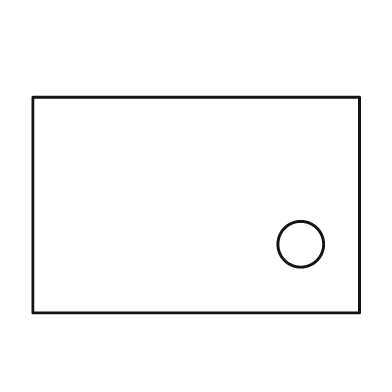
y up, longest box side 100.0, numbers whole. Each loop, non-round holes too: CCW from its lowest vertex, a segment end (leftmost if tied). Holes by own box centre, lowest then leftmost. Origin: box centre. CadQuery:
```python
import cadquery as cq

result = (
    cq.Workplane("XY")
    .moveTo(-50.0, -33.0)
    .lineTo(50.0, -33.0)
    .lineTo(50.0, 33.0)
    .lineTo(-50.0, 33.0)
    .close()
    .moveTo(32.0, -12.0)
    .circle(7.0)
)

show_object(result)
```